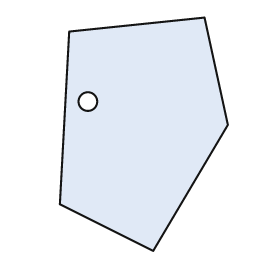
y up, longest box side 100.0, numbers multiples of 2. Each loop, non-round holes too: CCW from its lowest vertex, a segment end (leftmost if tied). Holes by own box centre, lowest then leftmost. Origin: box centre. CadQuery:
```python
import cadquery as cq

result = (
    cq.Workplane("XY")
    .moveTo(4.0, -50.0)
    .lineTo(36.0, 4.0)
    .lineTo(26.0, 50.0)
    .lineTo(-32.0, 44.0)
    .lineTo(-36.0, -30.0)
    .close()
    .moveTo(-24.0, 14.0)
    .circle(4.0)
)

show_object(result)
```